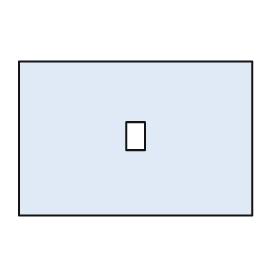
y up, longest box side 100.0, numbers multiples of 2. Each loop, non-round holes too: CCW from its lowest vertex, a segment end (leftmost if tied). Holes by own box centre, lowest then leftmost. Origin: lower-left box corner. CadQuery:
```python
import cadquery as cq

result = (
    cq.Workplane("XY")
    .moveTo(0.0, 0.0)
    .lineTo(100.0, 0.0)
    .lineTo(100.0, 66.0)
    .lineTo(0.0, 66.0)
    .close()
    .moveTo(46.0, 28.0)
    .lineTo(54.0, 28.0)
    .lineTo(54.0, 40.0)
    .lineTo(46.0, 40.0)
    .close()
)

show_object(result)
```